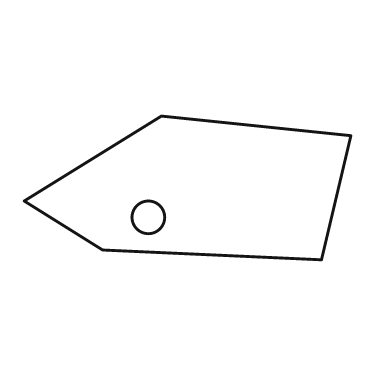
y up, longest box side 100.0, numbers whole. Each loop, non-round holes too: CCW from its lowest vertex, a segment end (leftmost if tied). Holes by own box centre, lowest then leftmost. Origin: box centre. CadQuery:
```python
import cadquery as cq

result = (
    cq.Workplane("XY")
    .moveTo(41.0, -22.0)
    .lineTo(50.0, 16.0)
    .lineTo(-8.0, 22.0)
    .lineTo(-50.0, -4.0)
    .lineTo(-26.0, -19.0)
    .close()
    .moveTo(-12.0, -9.0)
    .circle(5.0)
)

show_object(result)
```